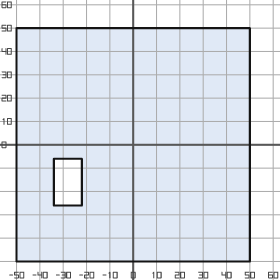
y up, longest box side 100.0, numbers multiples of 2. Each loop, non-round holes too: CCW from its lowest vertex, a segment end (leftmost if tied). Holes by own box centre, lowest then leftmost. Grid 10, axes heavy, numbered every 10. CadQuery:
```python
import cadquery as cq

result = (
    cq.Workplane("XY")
    .moveTo(-50.0, -50.0)
    .lineTo(50.0, -50.0)
    .lineTo(50.0, 50.0)
    .lineTo(-50.0, 50.0)
    .close()
    .moveTo(-34.0, -26.0)
    .lineTo(-22.0, -26.0)
    .lineTo(-22.0, -6.0)
    .lineTo(-34.0, -6.0)
    .close()
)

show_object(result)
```